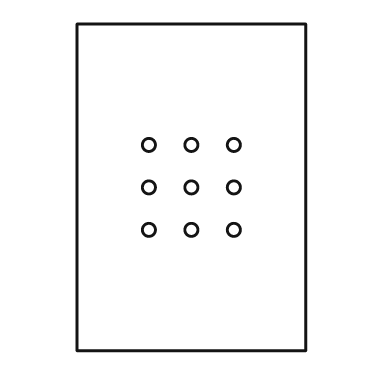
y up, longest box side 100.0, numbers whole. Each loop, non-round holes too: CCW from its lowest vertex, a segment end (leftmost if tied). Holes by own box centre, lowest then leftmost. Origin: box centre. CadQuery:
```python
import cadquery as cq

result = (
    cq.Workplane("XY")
    .moveTo(-35.0, -50.0)
    .lineTo(35.0, -50.0)
    .lineTo(35.0, 50.0)
    .lineTo(-35.0, 50.0)
    .close()
    .moveTo(-13.0, -13.0)
    .circle(2.0)
    .moveTo(0.0, -13.0)
    .circle(2.0)
    .moveTo(13.0, -13.0)
    .circle(2.0)
    .moveTo(-13.0, 0.0)
    .circle(2.0)
    .moveTo(0.0, 0.0)
    .circle(2.0)
    .moveTo(13.0, 0.0)
    .circle(2.0)
    .moveTo(-13.0, 13.0)
    .circle(2.0)
    .moveTo(0.0, 13.0)
    .circle(2.0)
    .moveTo(13.0, 13.0)
    .circle(2.0)
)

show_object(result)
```